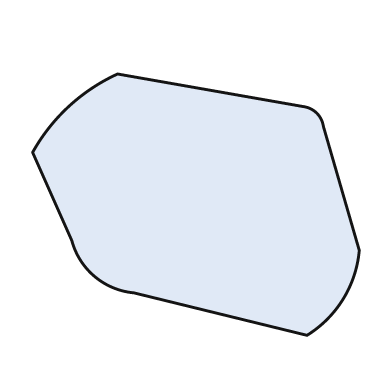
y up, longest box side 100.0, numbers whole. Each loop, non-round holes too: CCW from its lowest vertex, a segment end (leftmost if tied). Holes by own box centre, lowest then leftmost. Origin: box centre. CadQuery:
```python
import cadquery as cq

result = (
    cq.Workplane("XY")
    .moveTo(34.0, -40.0)
    .threePointArc((45.0, -29.0), (50.0, -14.0))
    .lineTo(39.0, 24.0)
    .threePointArc((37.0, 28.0), (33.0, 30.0))
    .lineTo(-24.0, 40.0)
    .threePointArc((-39.0, 30.0), (-50.0, 16.0))
    .lineTo(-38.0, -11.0)
    .threePointArc((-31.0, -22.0), (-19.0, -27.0))
    .close()
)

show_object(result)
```